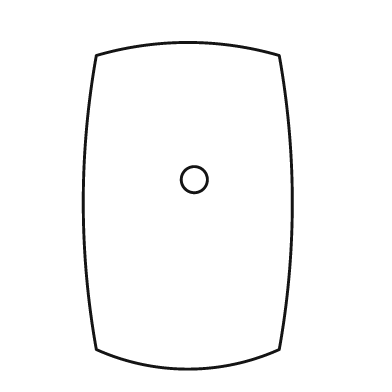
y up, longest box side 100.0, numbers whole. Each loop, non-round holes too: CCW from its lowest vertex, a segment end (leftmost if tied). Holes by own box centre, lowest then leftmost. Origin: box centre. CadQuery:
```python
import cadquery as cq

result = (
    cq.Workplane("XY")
    .moveTo(-28.0, -44.0)
    .threePointArc((0.0, -50.0), (28.0, -44.0))
    .threePointArc((32.0, 1.0), (28.0, 46.0))
    .threePointArc((0.0, 50.0), (-28.0, 46.0))
    .threePointArc((-32.0, 1.0), (-28.0, -44.0))
    .close()
    .moveTo(2.0, 8.0)
    .circle(4.0)
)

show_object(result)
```